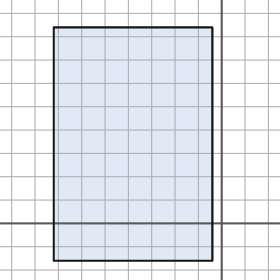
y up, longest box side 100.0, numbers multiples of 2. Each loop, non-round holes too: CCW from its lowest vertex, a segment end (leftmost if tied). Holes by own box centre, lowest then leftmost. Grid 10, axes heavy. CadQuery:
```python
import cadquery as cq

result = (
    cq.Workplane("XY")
    .moveTo(-72.0, -16.0)
    .lineTo(-4.0, -16.0)
    .lineTo(-4.0, 84.0)
    .lineTo(-72.0, 84.0)
    .close()
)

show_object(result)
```